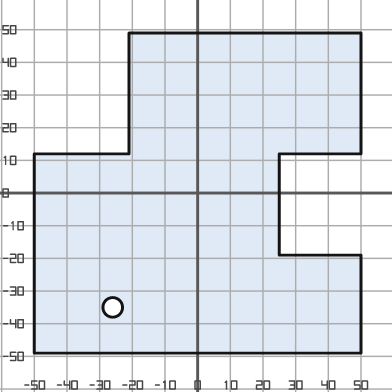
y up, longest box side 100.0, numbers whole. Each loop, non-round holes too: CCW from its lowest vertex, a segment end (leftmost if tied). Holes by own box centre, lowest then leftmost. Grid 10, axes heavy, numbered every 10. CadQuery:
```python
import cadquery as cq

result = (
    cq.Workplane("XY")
    .moveTo(-50.0, -49.0)
    .lineTo(50.0, -49.0)
    .lineTo(50.0, -19.0)
    .lineTo(25.0, -19.0)
    .lineTo(25.0, 12.0)
    .lineTo(50.0, 12.0)
    .lineTo(50.0, 49.0)
    .lineTo(-21.0, 49.0)
    .lineTo(-21.0, 12.0)
    .lineTo(-50.0, 12.0)
    .close()
    .moveTo(-26.0, -35.0)
    .circle(3.0)
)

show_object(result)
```